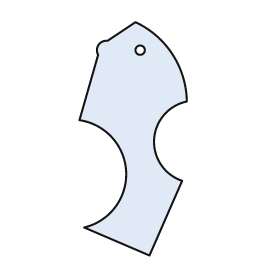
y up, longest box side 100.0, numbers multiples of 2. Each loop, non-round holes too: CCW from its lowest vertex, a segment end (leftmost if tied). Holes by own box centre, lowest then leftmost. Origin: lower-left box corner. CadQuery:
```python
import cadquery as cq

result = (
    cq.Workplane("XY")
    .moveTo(30.0, 0.0)
    .lineTo(44.0, 32.0)
    .threePointArc((32.0, 50.0), (46.0, 66.0))
    .threePointArc((40.0, 86.0), (24.0, 100.0))
    .lineTo(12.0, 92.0)
    .threePointArc((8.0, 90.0), (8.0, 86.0))
    .lineTo(0.0, 58.0)
    .threePointArc((20.0, 36.0), (2.0, 12.0))
    .close()
    .moveTo(26.0, 88.0)
    .circle(2.0)
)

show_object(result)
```